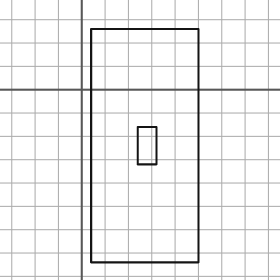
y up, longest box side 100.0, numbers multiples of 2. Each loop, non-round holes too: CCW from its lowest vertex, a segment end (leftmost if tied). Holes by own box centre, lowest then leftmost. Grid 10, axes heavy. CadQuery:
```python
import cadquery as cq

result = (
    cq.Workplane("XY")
    .moveTo(4.0, -74.0)
    .lineTo(50.0, -74.0)
    .lineTo(50.0, 26.0)
    .lineTo(4.0, 26.0)
    .close()
    .moveTo(24.0, -32.0)
    .lineTo(32.0, -32.0)
    .lineTo(32.0, -16.0)
    .lineTo(24.0, -16.0)
    .close()
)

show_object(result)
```